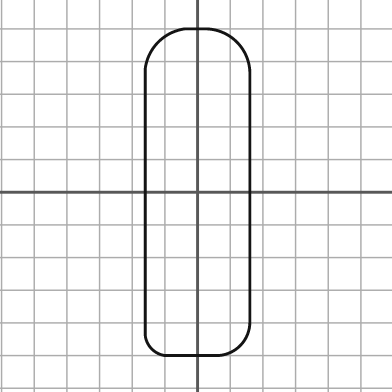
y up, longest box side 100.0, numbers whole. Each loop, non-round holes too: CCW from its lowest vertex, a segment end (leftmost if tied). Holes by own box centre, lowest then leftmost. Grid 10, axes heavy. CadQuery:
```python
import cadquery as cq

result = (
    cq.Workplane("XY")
    .moveTo(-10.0, -50.0)
    .lineTo(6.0, -50.0)
    .threePointArc((13.0, -47.0), (16.0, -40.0))
    .lineTo(16.0, 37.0)
    .threePointArc((12.0, 46.0), (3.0, 50.0))
    .lineTo(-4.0, 50.0)
    .threePointArc((-12.0, 46.0), (-16.0, 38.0))
    .lineTo(-16.0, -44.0)
    .threePointArc((-14.0, -48.0), (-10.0, -50.0))
    .close()
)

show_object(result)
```